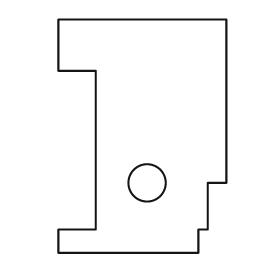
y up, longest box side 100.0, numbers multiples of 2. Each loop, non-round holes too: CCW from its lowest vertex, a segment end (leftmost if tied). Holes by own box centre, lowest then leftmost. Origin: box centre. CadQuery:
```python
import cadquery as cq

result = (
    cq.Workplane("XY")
    .moveTo(-36.0, -50.0)
    .lineTo(24.0, -50.0)
    .lineTo(24.0, -40.0)
    .lineTo(28.0, -40.0)
    .lineTo(28.0, -20.0)
    .lineTo(36.0, -20.0)
    .lineTo(36.0, 50.0)
    .lineTo(-36.0, 50.0)
    .lineTo(-36.0, 28.0)
    .lineTo(-20.0, 28.0)
    .lineTo(-20.0, -40.0)
    .lineTo(-36.0, -40.0)
    .close()
    .moveTo(2.0, -20.0)
    .circle(8.0)
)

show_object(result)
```